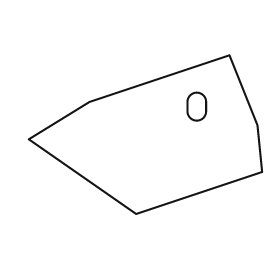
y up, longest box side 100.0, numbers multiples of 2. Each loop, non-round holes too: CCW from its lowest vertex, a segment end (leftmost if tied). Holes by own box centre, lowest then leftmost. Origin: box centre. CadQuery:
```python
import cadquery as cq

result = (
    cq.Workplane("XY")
    .moveTo(-4.0, -34.0)
    .lineTo(50.0, -16.0)
    .lineTo(48.0, 4.0)
    .lineTo(36.0, 34.0)
    .lineTo(-24.0, 14.0)
    .lineTo(-50.0, -2.0)
    .close()
    .moveTo(18.0, 10.0)
    .threePointArc((22.0, 6.0), (26.0, 10.0))
    .lineTo(26.0, 14.0)
    .threePointArc((22.0, 18.0), (18.0, 14.0))
    .close()
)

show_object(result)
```